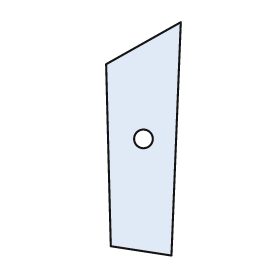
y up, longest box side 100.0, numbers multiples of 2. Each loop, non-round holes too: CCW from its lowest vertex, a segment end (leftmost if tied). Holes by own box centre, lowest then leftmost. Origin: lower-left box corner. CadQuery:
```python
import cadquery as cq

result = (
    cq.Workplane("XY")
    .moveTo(28.0, 0.0)
    .lineTo(32.0, 100.0)
    .lineTo(0.0, 82.0)
    .lineTo(2.0, 4.0)
    .close()
    .moveTo(16.0, 50.0)
    .circle(4.0)
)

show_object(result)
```